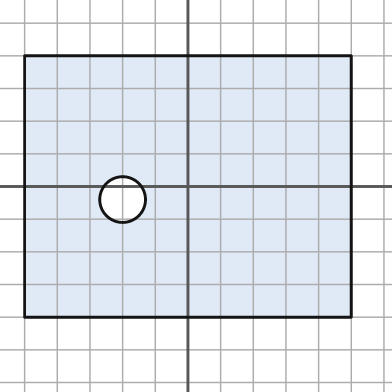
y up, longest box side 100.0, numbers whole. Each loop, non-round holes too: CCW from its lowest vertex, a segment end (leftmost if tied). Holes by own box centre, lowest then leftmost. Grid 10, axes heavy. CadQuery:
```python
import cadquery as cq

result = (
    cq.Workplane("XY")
    .moveTo(-50.0, -40.0)
    .lineTo(50.0, -40.0)
    .lineTo(50.0, 40.0)
    .lineTo(-50.0, 40.0)
    .close()
    .moveTo(-20.0, -4.0)
    .circle(7.0)
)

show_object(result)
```